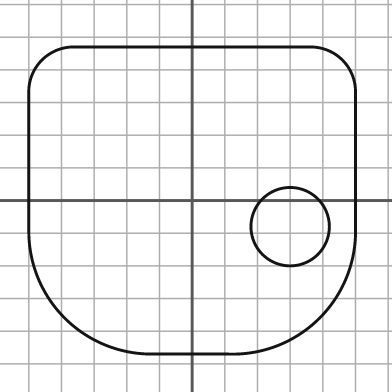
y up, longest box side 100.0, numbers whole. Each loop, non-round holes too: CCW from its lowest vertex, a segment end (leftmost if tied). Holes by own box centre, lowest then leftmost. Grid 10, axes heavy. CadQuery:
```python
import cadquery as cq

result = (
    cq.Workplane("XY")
    .moveTo(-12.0, -47.0)
    .lineTo(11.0, -47.0)
    .threePointArc((39.0, -36.0), (50.0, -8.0))
    .lineTo(50.0, 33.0)
    .threePointArc((46.0, 43.0), (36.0, 47.0))
    .lineTo(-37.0, 47.0)
    .threePointArc((-46.0, 43.0), (-50.0, 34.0))
    .lineTo(-50.0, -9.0)
    .threePointArc((-39.0, -36.0), (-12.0, -47.0))
    .close()
    .moveTo(30.0, -8.0)
    .circle(12.0)
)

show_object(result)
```